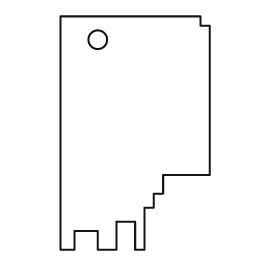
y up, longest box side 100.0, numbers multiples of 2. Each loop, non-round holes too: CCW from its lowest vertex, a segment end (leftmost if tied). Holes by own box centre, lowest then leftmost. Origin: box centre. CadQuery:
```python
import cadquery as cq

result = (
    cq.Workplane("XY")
    .moveTo(-32.0, -50.0)
    .lineTo(-26.0, -50.0)
    .lineTo(-26.0, -42.0)
    .lineTo(-16.0, -42.0)
    .lineTo(-16.0, -50.0)
    .lineTo(-8.0, -50.0)
    .lineTo(-8.0, -38.0)
    .lineTo(0.0, -38.0)
    .lineTo(0.0, -50.0)
    .lineTo(4.0, -50.0)
    .lineTo(4.0, -32.0)
    .lineTo(8.0, -32.0)
    .lineTo(8.0, -26.0)
    .lineTo(12.0, -26.0)
    .lineTo(12.0, -18.0)
    .lineTo(32.0, -18.0)
    .lineTo(32.0, 46.0)
    .lineTo(28.0, 46.0)
    .lineTo(28.0, 50.0)
    .lineTo(-32.0, 50.0)
    .close()
    .moveTo(-16.0, 40.0)
    .circle(4.0)
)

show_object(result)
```